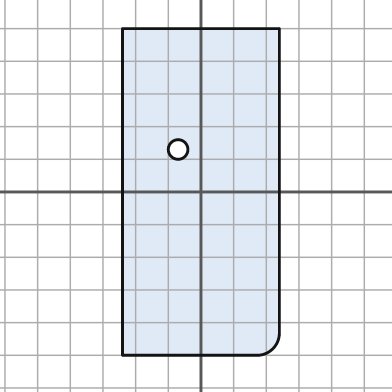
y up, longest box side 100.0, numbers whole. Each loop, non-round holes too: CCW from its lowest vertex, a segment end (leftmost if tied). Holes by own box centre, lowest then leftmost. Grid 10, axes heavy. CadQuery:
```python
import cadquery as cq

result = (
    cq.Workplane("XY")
    .moveTo(-24.0, -50.0)
    .lineTo(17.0, -50.0)
    .threePointArc((22.0, -48.0), (24.0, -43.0))
    .lineTo(24.0, 50.0)
    .lineTo(-24.0, 50.0)
    .close()
    .moveTo(-7.0, 13.0)
    .circle(3.0)
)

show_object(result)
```